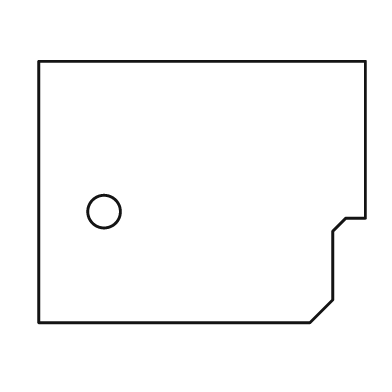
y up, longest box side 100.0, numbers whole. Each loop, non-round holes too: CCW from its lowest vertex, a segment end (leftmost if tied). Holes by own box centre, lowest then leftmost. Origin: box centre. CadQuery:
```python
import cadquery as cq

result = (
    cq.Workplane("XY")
    .moveTo(-50.0, -40.0)
    .lineTo(33.0, -40.0)
    .lineTo(40.0, -33.0)
    .lineTo(40.0, -12.0)
    .lineTo(44.0, -8.0)
    .lineTo(50.0, -8.0)
    .lineTo(50.0, 40.0)
    .lineTo(-50.0, 40.0)
    .close()
    .moveTo(-30.0, -6.0)
    .circle(5.0)
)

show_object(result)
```